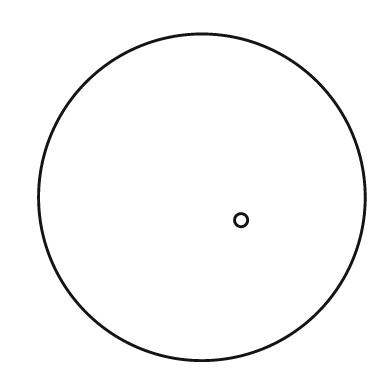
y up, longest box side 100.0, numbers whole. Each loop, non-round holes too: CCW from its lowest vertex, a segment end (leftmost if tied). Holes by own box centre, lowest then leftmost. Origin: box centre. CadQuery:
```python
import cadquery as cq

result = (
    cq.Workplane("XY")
    .moveTo(0.0, 0.0)
    .circle(50.0)
    .moveTo(12.0, -7.0)
    .circle(2.0)
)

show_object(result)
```